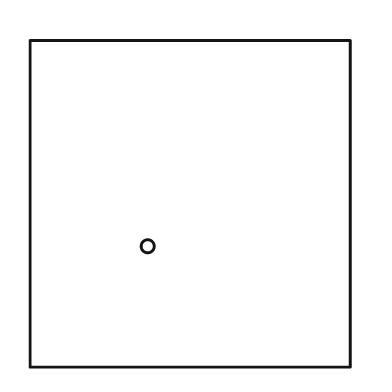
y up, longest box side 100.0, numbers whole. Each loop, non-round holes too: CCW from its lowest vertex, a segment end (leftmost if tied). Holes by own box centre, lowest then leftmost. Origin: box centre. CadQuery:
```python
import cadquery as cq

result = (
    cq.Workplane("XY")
    .moveTo(-49.0, -50.0)
    .lineTo(49.0, -50.0)
    .lineTo(49.0, 50.0)
    .lineTo(-49.0, 50.0)
    .close()
    .moveTo(-13.0, -13.0)
    .circle(2.0)
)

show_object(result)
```